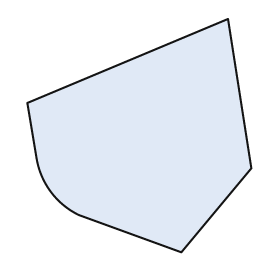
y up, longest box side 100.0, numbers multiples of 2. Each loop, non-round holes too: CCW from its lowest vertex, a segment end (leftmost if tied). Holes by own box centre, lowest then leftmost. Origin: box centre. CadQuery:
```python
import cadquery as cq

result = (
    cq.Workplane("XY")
    .moveTo(18.0, -50.0)
    .lineTo(48.0, -14.0)
    .lineTo(38.0, 50.0)
    .lineTo(-48.0, 14.0)
    .lineTo(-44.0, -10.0)
    .threePointArc((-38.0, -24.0), (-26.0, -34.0))
    .close()
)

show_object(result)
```